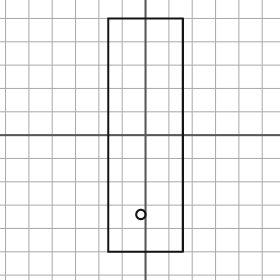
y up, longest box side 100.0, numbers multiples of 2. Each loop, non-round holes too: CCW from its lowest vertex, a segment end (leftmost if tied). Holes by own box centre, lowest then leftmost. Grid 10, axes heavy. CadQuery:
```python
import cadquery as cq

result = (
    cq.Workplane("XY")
    .moveTo(-16.0, -50.0)
    .lineTo(16.0, -50.0)
    .lineTo(16.0, 50.0)
    .lineTo(-16.0, 50.0)
    .close()
    .moveTo(-2.0, -34.0)
    .circle(2.0)
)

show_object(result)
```